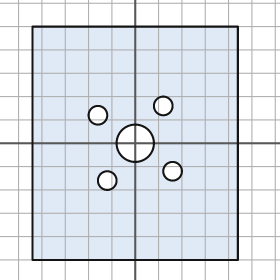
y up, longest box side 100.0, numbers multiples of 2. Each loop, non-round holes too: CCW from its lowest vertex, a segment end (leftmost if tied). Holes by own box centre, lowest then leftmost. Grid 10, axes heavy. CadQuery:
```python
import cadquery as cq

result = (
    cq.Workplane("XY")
    .moveTo(-44.0, -50.0)
    .lineTo(44.0, -50.0)
    .lineTo(44.0, 50.0)
    .lineTo(-44.0, 50.0)
    .close()
    .moveTo(-12.0, -16.0)
    .circle(4.0)
    .moveTo(16.0, -12.0)
    .circle(4.0)
    .moveTo(0.0, 0.0)
    .circle(8.0)
    .moveTo(-16.0, 12.0)
    .circle(4.0)
    .moveTo(12.0, 16.0)
    .circle(4.0)
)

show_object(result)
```